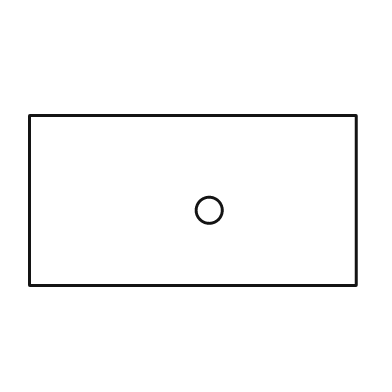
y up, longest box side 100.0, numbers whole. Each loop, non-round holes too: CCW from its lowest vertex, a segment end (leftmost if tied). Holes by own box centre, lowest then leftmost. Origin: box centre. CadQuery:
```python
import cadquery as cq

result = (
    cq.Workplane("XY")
    .moveTo(-50.0, -26.0)
    .lineTo(50.0, -26.0)
    .lineTo(50.0, 26.0)
    .lineTo(-50.0, 26.0)
    .close()
    .moveTo(5.0, -3.0)
    .circle(4.0)
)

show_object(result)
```